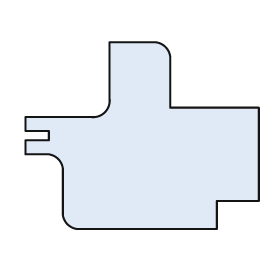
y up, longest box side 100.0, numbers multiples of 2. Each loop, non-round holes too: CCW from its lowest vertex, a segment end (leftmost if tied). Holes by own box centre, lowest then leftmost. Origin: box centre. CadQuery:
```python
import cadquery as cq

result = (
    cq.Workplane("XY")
    .moveTo(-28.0, -40.0)
    .lineTo(32.0, -40.0)
    .lineTo(32.0, -28.0)
    .lineTo(50.0, -28.0)
    .lineTo(50.0, 12.0)
    .lineTo(12.0, 12.0)
    .lineTo(12.0, 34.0)
    .threePointArc((10.0, 38.0), (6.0, 40.0))
    .lineTo(-14.0, 40.0)
    .lineTo(-14.0, 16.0)
    .threePointArc((-16.0, 10.0), (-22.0, 8.0))
    .lineTo(-50.0, 8.0)
    .lineTo(-50.0, 2.0)
    .lineTo(-40.0, 2.0)
    .lineTo(-40.0, -2.0)
    .lineTo(-50.0, -2.0)
    .lineTo(-50.0, -8.0)
    .lineTo(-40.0, -8.0)
    .threePointArc((-36.0, -10.0), (-34.0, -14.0))
    .lineTo(-34.0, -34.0)
    .threePointArc((-32.0, -38.0), (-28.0, -40.0))
    .close()
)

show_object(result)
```